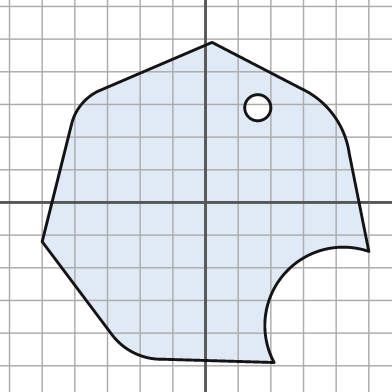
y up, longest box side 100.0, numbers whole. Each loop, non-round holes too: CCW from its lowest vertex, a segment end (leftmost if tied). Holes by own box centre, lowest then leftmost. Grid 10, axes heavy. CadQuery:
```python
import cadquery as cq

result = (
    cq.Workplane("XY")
    .moveTo(21.0, -49.0)
    .threePointArc((24.0, -22.0), (50.0, -15.0))
    .lineTo(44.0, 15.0)
    .threePointArc((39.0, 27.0), (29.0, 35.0))
    .lineTo(2.0, 49.0)
    .lineTo(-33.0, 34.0)
    .threePointArc((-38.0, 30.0), (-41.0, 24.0))
    .lineTo(-50.0, -12.0)
    .lineTo(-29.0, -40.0)
    .threePointArc((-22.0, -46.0), (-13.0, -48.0))
    .close()
    .moveTo(16.0, 29.0)
    .circle(4.0)
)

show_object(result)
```